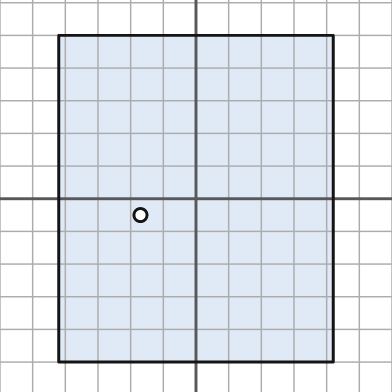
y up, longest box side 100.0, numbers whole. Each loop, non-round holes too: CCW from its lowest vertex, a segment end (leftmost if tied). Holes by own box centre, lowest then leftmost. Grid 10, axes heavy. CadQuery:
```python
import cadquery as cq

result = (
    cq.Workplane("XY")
    .moveTo(-42.0, -50.0)
    .lineTo(42.0, -50.0)
    .lineTo(42.0, 50.0)
    .lineTo(-42.0, 50.0)
    .close()
    .moveTo(-17.0, -5.0)
    .circle(2.0)
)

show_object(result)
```